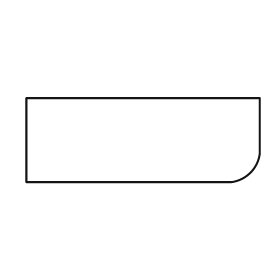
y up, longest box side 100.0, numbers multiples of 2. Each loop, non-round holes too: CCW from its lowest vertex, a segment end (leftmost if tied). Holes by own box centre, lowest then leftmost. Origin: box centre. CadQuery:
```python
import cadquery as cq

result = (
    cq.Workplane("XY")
    .moveTo(-50.0, -18.0)
    .lineTo(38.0, -18.0)
    .threePointArc((46.0, -14.0), (50.0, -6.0))
    .lineTo(50.0, 18.0)
    .lineTo(-50.0, 18.0)
    .close()
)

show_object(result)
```